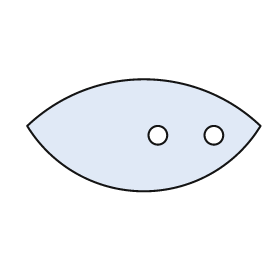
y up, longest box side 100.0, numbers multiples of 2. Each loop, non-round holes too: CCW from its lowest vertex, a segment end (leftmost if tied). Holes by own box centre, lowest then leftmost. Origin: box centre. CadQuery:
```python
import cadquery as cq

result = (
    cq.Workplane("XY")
    .moveTo(-50.0, 4.0)
    .threePointArc((0.0, -24.0), (50.0, 4.0))
    .threePointArc((0.0, 24.0), (-50.0, 4.0))
    .close()
    .moveTo(6.0, 0.0)
    .circle(4.0)
    .moveTo(30.0, 0.0)
    .circle(4.0)
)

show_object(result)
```